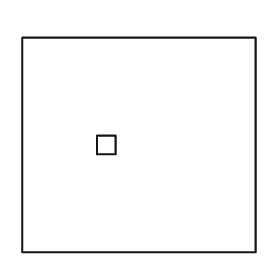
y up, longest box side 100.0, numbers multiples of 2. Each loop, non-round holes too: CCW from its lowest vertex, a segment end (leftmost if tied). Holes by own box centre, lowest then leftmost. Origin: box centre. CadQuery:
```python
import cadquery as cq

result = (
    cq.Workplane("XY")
    .moveTo(-50.0, -46.0)
    .lineTo(50.0, -46.0)
    .lineTo(50.0, 46.0)
    .lineTo(-50.0, 46.0)
    .close()
    .moveTo(-18.0, -4.0)
    .lineTo(-10.0, -4.0)
    .lineTo(-10.0, 4.0)
    .lineTo(-18.0, 4.0)
    .close()
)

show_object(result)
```